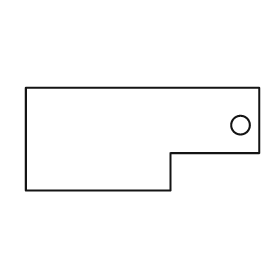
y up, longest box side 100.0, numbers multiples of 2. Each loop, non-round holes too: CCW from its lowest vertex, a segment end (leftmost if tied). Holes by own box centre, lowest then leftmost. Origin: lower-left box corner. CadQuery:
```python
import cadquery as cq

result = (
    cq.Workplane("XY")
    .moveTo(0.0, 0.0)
    .lineTo(62.0, 0.0)
    .lineTo(62.0, 16.0)
    .lineTo(100.0, 16.0)
    .lineTo(100.0, 44.0)
    .lineTo(0.0, 44.0)
    .close()
    .moveTo(92.0, 28.0)
    .circle(4.0)
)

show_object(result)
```